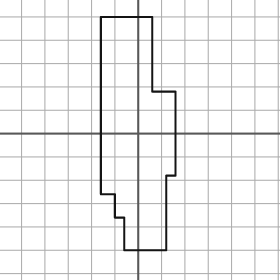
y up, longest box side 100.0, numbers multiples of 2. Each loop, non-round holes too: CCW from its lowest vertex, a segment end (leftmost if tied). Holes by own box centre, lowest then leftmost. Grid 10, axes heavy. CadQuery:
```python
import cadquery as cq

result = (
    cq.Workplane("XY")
    .moveTo(-6.0, -50.0)
    .lineTo(12.0, -50.0)
    .lineTo(12.0, -18.0)
    .lineTo(16.0, -18.0)
    .lineTo(16.0, 18.0)
    .lineTo(6.0, 18.0)
    .lineTo(6.0, 50.0)
    .lineTo(-16.0, 50.0)
    .lineTo(-16.0, -26.0)
    .lineTo(-10.0, -26.0)
    .lineTo(-10.0, -36.0)
    .lineTo(-6.0, -36.0)
    .close()
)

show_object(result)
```